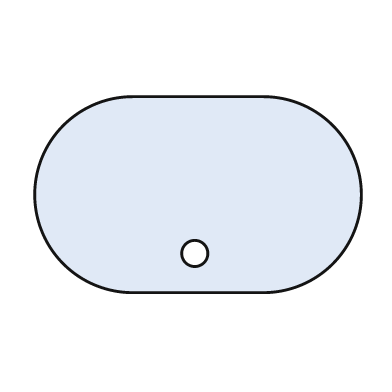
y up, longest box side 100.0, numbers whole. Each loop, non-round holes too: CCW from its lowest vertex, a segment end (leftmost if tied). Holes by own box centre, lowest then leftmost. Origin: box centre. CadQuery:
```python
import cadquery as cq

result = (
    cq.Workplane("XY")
    .moveTo(-20.0, -30.0)
    .lineTo(20.0, -30.0)
    .threePointArc((50.0, 0.0), (20.0, 30.0))
    .lineTo(-20.0, 30.0)
    .threePointArc((-50.0, 0.0), (-20.0, -30.0))
    .close()
    .moveTo(-1.0, -18.0)
    .circle(4.0)
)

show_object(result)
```